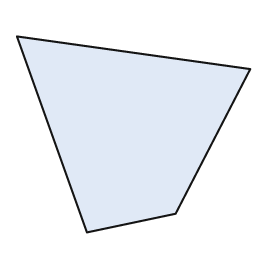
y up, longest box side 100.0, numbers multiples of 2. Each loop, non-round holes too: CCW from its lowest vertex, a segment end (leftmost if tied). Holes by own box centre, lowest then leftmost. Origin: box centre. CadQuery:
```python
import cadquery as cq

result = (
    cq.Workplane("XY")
    .moveTo(-20.0, -42.0)
    .lineTo(18.0, -34.0)
    .lineTo(50.0, 28.0)
    .lineTo(-50.0, 42.0)
    .close()
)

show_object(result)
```